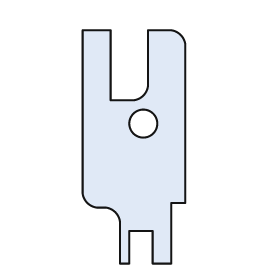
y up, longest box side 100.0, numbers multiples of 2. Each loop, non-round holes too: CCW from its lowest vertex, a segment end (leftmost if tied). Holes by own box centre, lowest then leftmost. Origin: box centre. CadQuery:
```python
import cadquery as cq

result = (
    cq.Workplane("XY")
    .moveTo(-6.0, -50.0)
    .lineTo(-2.0, -50.0)
    .lineTo(-2.0, -36.0)
    .lineTo(8.0, -36.0)
    .lineTo(8.0, -50.0)
    .lineTo(16.0, -50.0)
    .lineTo(16.0, -24.0)
    .lineTo(22.0, -24.0)
    .lineTo(22.0, 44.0)
    .threePointArc((20.0, 48.0), (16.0, 50.0))
    .lineTo(6.0, 50.0)
    .lineTo(6.0, 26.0)
    .threePointArc((4.0, 22.0), (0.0, 20.0))
    .lineTo(-10.0, 20.0)
    .lineTo(-10.0, 50.0)
    .lineTo(-22.0, 50.0)
    .lineTo(-22.0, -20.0)
    .threePointArc((-20.0, -24.0), (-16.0, -26.0))
    .lineTo(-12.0, -26.0)
    .threePointArc((-8.0, -28.0), (-6.0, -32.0))
    .close()
    .moveTo(4.0, 10.0)
    .circle(6.0)
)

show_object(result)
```